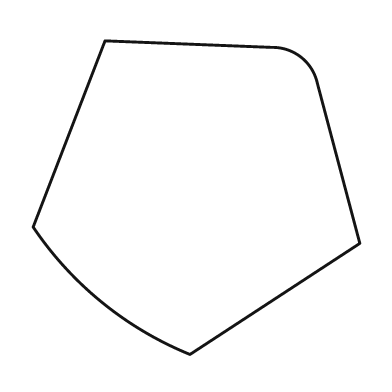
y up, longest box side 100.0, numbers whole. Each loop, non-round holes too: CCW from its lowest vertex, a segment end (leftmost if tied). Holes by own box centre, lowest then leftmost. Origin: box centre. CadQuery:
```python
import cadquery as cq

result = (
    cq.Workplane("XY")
    .moveTo(-2.0, -48.0)
    .lineTo(50.0, -14.0)
    .lineTo(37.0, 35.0)
    .threePointArc((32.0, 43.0), (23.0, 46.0))
    .lineTo(-28.0, 48.0)
    .lineTo(-50.0, -9.0)
    .threePointArc((-29.0, -32.0), (-2.0, -48.0))
    .close()
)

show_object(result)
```